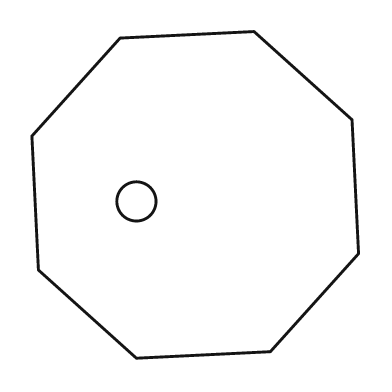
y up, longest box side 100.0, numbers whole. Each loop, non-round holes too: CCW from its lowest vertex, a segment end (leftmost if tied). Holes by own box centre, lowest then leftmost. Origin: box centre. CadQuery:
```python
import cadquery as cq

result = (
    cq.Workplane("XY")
    .moveTo(-18.0, -50.0)
    .lineTo(23.0, -48.0)
    .lineTo(50.0, -18.0)
    .lineTo(48.0, 23.0)
    .lineTo(18.0, 50.0)
    .lineTo(-23.0, 48.0)
    .lineTo(-50.0, 18.0)
    .lineTo(-48.0, -23.0)
    .close()
    .moveTo(-18.0, -2.0)
    .circle(6.0)
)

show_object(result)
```